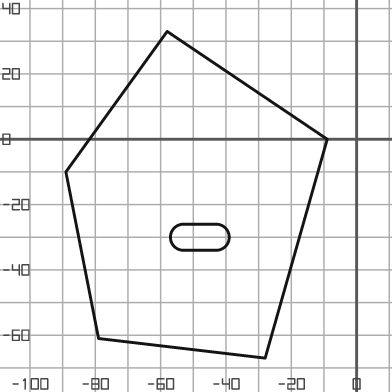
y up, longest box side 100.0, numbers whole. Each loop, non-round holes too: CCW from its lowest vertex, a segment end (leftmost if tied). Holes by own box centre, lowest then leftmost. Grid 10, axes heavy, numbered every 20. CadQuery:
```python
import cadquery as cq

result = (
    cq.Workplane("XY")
    .moveTo(-28.0, -67.0)
    .lineTo(-9.0, 0.0)
    .lineTo(-58.0, 33.0)
    .lineTo(-89.0, -10.0)
    .lineTo(-79.0, -61.0)
    .close()
    .moveTo(-53.0, -34.0)
    .lineTo(-43.0, -34.0)
    .threePointArc((-39.0, -30.0), (-43.0, -26.0))
    .lineTo(-53.0, -26.0)
    .threePointArc((-57.0, -30.0), (-53.0, -34.0))
    .close()
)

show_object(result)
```